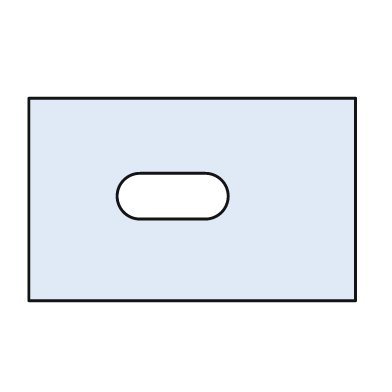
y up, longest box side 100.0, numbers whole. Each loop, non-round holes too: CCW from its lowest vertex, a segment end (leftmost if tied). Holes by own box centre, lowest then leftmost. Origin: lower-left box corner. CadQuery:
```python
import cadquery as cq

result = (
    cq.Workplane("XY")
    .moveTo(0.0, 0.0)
    .lineTo(100.0, 0.0)
    .lineTo(100.0, 62.0)
    .lineTo(0.0, 62.0)
    .close()
    .moveTo(34.0, 25.0)
    .lineTo(54.0, 25.0)
    .threePointArc((61.0, 32.0), (54.0, 39.0))
    .lineTo(34.0, 39.0)
    .threePointArc((27.0, 32.0), (34.0, 25.0))
    .close()
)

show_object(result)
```